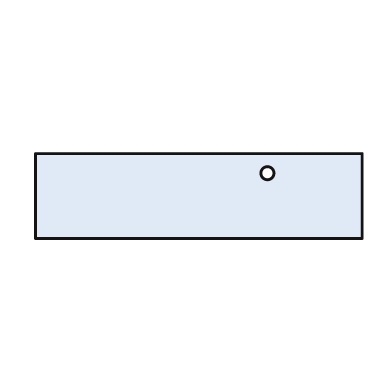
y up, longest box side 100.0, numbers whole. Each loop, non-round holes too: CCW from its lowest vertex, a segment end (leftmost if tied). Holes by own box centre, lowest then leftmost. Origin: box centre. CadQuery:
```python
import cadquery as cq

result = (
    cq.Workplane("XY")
    .moveTo(-50.0, -13.0)
    .lineTo(50.0, -13.0)
    .lineTo(50.0, 13.0)
    .lineTo(-50.0, 13.0)
    .close()
    .moveTo(21.0, 7.0)
    .circle(2.0)
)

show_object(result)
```